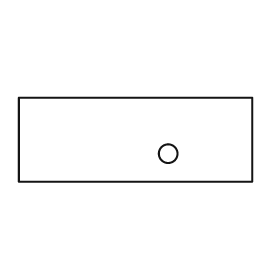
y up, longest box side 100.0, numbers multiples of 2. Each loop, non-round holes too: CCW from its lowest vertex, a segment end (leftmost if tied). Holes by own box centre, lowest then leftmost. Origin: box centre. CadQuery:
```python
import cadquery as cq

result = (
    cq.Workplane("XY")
    .moveTo(-50.0, -18.0)
    .lineTo(50.0, -18.0)
    .lineTo(50.0, 18.0)
    .lineTo(-50.0, 18.0)
    .close()
    .moveTo(14.0, -6.0)
    .circle(4.0)
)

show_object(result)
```